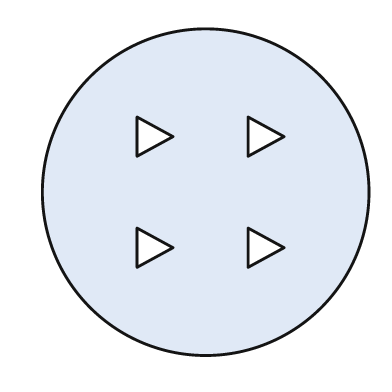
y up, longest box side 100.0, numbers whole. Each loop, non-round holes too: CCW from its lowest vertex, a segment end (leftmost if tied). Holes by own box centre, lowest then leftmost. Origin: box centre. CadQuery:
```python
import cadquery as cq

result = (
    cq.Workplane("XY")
    .moveTo(0.0, 0.0)
    .circle(50.0)
    .moveTo(-21.0, -23.0)
    .lineTo(-10.0, -17.0)
    .lineTo(-21.0, -11.0)
    .close()
    .moveTo(13.0, -23.0)
    .lineTo(24.0, -17.0)
    .lineTo(13.0, -11.0)
    .close()
    .moveTo(-21.0, 11.0)
    .lineTo(-10.0, 17.0)
    .lineTo(-21.0, 23.0)
    .close()
    .moveTo(13.0, 11.0)
    .lineTo(24.0, 17.0)
    .lineTo(13.0, 23.0)
    .close()
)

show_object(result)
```